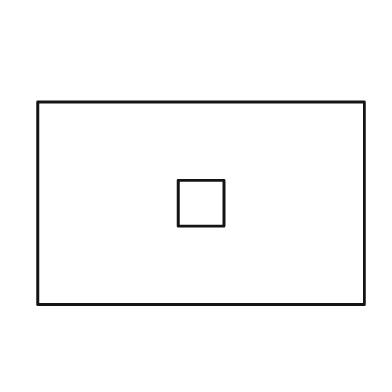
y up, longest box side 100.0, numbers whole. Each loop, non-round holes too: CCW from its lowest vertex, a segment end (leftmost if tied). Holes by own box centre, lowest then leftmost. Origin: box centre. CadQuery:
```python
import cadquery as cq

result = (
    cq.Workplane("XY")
    .moveTo(-50.0, -31.0)
    .lineTo(50.0, -31.0)
    .lineTo(50.0, 31.0)
    .lineTo(-50.0, 31.0)
    .close()
    .moveTo(-7.0, -7.0)
    .lineTo(7.0, -7.0)
    .lineTo(7.0, 7.0)
    .lineTo(-7.0, 7.0)
    .close()
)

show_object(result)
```